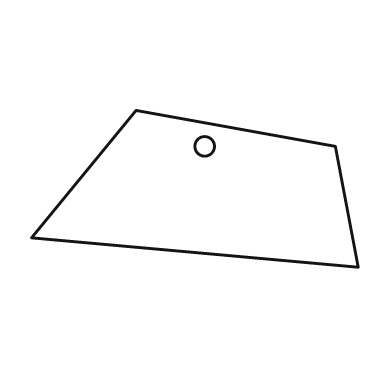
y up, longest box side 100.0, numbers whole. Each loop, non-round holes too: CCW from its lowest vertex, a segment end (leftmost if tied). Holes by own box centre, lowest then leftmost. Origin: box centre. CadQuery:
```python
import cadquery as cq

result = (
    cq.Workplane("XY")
    .moveTo(50.0, -24.0)
    .lineTo(43.0, 13.0)
    .lineTo(-18.0, 24.0)
    .lineTo(-50.0, -15.0)
    .close()
    .moveTo(3.0, 13.0)
    .circle(3.0)
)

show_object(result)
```